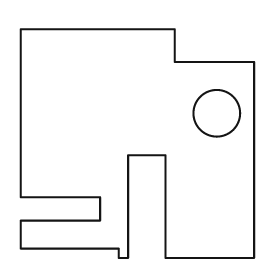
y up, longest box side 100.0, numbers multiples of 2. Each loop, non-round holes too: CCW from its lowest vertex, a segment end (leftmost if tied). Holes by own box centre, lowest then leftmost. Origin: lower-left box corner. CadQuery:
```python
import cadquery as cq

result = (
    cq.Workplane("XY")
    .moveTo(42.0, 0.0)
    .lineTo(46.0, 0.0)
    .lineTo(46.0, 44.0)
    .lineTo(62.0, 44.0)
    .lineTo(62.0, 0.0)
    .lineTo(100.0, 0.0)
    .lineTo(100.0, 84.0)
    .lineTo(66.0, 84.0)
    .lineTo(66.0, 98.0)
    .lineTo(0.0, 98.0)
    .lineTo(0.0, 26.0)
    .lineTo(34.0, 26.0)
    .lineTo(34.0, 16.0)
    .lineTo(0.0, 16.0)
    .lineTo(0.0, 4.0)
    .lineTo(42.0, 4.0)
    .close()
    .moveTo(84.0, 62.0)
    .circle(10.0)
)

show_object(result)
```